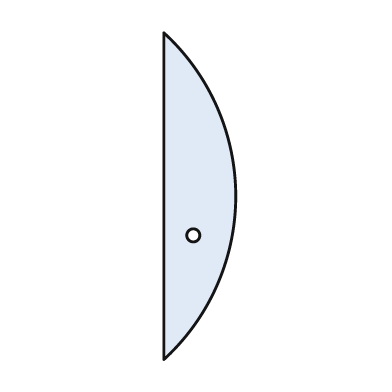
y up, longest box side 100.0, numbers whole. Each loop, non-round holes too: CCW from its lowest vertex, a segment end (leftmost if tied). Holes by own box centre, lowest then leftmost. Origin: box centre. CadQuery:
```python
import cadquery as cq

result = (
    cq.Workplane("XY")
    .moveTo(-11.0, -50.0)
    .threePointArc((11.0, 0.0), (-11.0, 50.0))
    .close()
    .moveTo(-2.0, -12.0)
    .circle(2.0)
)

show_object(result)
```